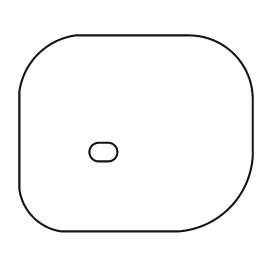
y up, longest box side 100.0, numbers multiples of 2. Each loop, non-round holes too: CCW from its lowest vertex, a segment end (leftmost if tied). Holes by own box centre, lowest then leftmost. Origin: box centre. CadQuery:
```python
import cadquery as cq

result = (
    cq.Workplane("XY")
    .moveTo(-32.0, -42.0)
    .lineTo(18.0, -42.0)
    .threePointArc((40.0, -32.0), (50.0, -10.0))
    .lineTo(50.0, 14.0)
    .threePointArc((42.0, 34.0), (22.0, 42.0))
    .lineTo(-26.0, 42.0)
    .threePointArc((-42.0, 34.0), (-50.0, 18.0))
    .lineTo(-50.0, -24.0)
    .threePointArc((-44.0, -36.0), (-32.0, -42.0))
    .close()
    .moveTo(-16.0, -12.0)
    .lineTo(-12.0, -12.0)
    .threePointArc((-8.0, -8.0), (-12.0, -4.0))
    .lineTo(-16.0, -4.0)
    .threePointArc((-20.0, -8.0), (-16.0, -12.0))
    .close()
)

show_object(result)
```